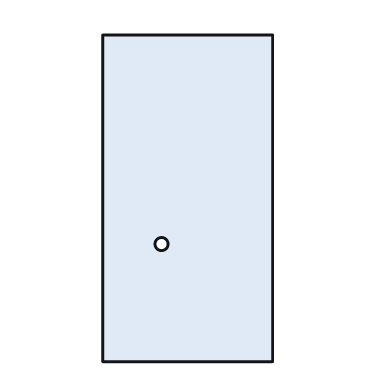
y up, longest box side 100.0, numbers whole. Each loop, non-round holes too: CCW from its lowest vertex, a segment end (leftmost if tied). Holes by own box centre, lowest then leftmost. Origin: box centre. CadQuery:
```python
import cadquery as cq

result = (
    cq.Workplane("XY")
    .moveTo(-26.0, -50.0)
    .lineTo(26.0, -50.0)
    .lineTo(26.0, 50.0)
    .lineTo(-26.0, 50.0)
    .close()
    .moveTo(-8.0, -14.0)
    .circle(2.0)
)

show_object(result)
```